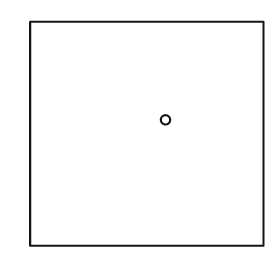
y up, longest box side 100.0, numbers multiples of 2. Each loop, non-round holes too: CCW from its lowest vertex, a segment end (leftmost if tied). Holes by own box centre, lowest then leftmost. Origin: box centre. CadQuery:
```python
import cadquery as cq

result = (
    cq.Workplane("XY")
    .moveTo(-50.0, -48.0)
    .lineTo(50.0, -48.0)
    .lineTo(50.0, 48.0)
    .lineTo(-50.0, 48.0)
    .close()
    .moveTo(8.0, 6.0)
    .circle(2.0)
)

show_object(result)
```